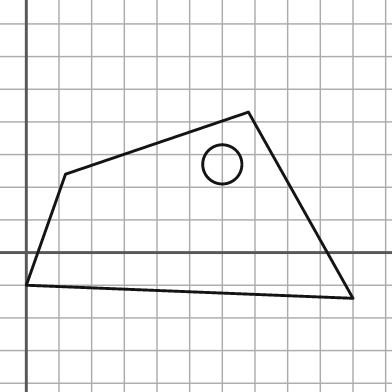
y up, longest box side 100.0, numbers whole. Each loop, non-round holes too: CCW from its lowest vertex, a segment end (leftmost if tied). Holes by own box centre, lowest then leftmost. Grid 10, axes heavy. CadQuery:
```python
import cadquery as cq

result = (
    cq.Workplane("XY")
    .moveTo(100.0, -14.0)
    .lineTo(68.0, 43.0)
    .lineTo(12.0, 24.0)
    .lineTo(0.0, -10.0)
    .close()
    .moveTo(60.0, 27.0)
    .circle(6.0)
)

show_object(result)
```